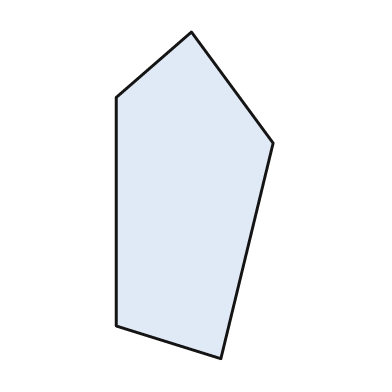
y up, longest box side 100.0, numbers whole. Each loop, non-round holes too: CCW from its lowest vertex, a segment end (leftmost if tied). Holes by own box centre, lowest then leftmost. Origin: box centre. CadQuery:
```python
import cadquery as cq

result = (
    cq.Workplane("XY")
    .moveTo(8.0, -50.0)
    .lineTo(24.0, 16.0)
    .lineTo(-1.0, 50.0)
    .lineTo(-24.0, 30.0)
    .lineTo(-24.0, -40.0)
    .close()
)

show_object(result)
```